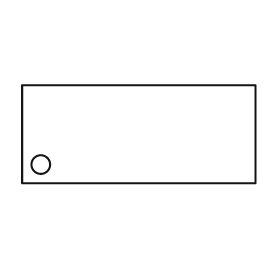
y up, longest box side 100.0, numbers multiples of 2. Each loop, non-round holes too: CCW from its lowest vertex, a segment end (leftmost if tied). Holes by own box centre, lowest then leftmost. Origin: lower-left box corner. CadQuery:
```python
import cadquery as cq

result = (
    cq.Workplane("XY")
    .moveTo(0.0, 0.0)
    .lineTo(100.0, 0.0)
    .lineTo(100.0, 42.0)
    .lineTo(0.0, 42.0)
    .close()
    .moveTo(8.0, 8.0)
    .circle(4.0)
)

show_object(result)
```